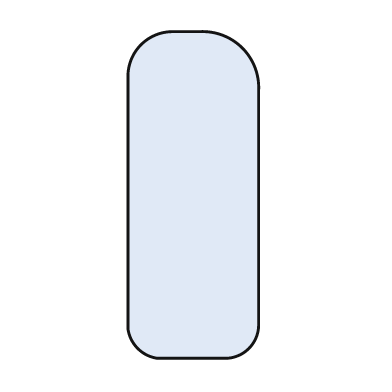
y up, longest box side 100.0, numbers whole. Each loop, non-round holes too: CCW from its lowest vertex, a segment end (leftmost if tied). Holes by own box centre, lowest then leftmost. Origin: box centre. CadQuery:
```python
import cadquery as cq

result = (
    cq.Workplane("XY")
    .moveTo(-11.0, -50.0)
    .lineTo(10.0, -50.0)
    .threePointArc((17.0, -47.0), (20.0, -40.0))
    .lineTo(20.0, 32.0)
    .threePointArc((15.0, 45.0), (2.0, 50.0))
    .lineTo(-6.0, 50.0)
    .threePointArc((-16.0, 46.0), (-20.0, 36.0))
    .lineTo(-20.0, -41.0)
    .threePointArc((-17.0, -47.0), (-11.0, -50.0))
    .close()
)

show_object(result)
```